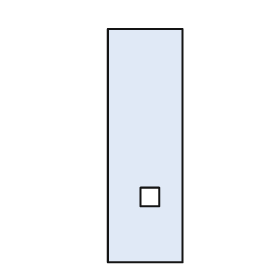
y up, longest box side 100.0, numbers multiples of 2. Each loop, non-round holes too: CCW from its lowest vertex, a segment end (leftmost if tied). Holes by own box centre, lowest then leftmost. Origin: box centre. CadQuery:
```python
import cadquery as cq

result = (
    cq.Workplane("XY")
    .moveTo(-16.0, -50.0)
    .lineTo(16.0, -50.0)
    .lineTo(16.0, 50.0)
    .lineTo(-16.0, 50.0)
    .close()
    .moveTo(-2.0, -26.0)
    .lineTo(6.0, -26.0)
    .lineTo(6.0, -18.0)
    .lineTo(-2.0, -18.0)
    .close()
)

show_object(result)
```